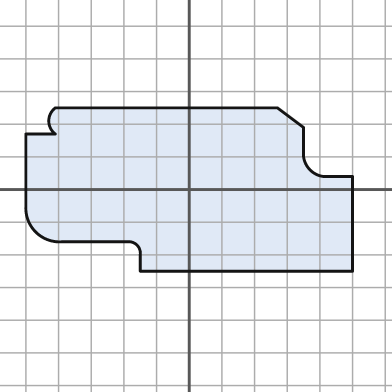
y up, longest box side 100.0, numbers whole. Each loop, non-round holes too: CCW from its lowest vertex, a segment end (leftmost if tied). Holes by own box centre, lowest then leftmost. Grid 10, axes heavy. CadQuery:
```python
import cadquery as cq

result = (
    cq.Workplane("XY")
    .moveTo(-15.0, -25.0)
    .lineTo(50.0, -25.0)
    .lineTo(50.0, 4.0)
    .lineTo(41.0, 4.0)
    .threePointArc((37.0, 6.0), (35.0, 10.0))
    .lineTo(35.0, 19.0)
    .lineTo(27.0, 25.0)
    .lineTo(-41.0, 25.0)
    .threePointArc((-43.0, 21.0), (-41.0, 17.0))
    .lineTo(-50.0, 17.0)
    .lineTo(-50.0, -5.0)
    .threePointArc((-47.0, -13.0), (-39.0, -16.0))
    .lineTo(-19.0, -16.0)
    .threePointArc((-16.0, -17.0), (-15.0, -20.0))
    .close()
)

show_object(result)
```